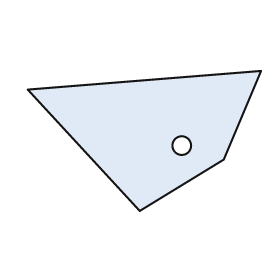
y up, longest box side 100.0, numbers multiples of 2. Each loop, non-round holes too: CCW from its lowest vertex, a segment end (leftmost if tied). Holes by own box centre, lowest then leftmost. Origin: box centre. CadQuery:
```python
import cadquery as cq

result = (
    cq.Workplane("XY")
    .moveTo(-2.0, -30.0)
    .lineTo(34.0, -8.0)
    .lineTo(50.0, 30.0)
    .lineTo(-50.0, 22.0)
    .close()
    .moveTo(16.0, -2.0)
    .circle(4.0)
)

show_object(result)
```